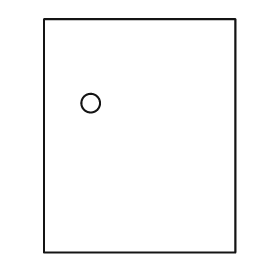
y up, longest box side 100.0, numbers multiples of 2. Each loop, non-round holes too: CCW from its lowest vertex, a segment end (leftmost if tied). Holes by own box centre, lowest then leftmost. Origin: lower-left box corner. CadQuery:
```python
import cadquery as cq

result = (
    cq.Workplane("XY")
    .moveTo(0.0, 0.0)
    .lineTo(82.0, 0.0)
    .lineTo(82.0, 100.0)
    .lineTo(0.0, 100.0)
    .close()
    .moveTo(20.0, 64.0)
    .circle(4.0)
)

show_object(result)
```